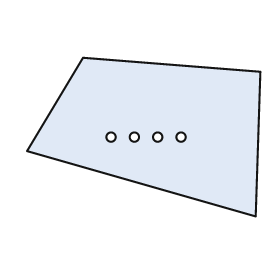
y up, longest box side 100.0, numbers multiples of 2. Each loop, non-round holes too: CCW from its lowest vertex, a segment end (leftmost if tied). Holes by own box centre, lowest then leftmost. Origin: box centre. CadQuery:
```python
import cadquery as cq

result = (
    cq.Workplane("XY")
    .moveTo(48.0, -34.0)
    .lineTo(50.0, 28.0)
    .lineTo(-26.0, 34.0)
    .lineTo(-50.0, -6.0)
    .close()
    .moveTo(-14.0, 0.0)
    .circle(2.0)
    .moveTo(-4.0, 0.0)
    .circle(2.0)
    .moveTo(6.0, 0.0)
    .circle(2.0)
    .moveTo(16.0, 0.0)
    .circle(2.0)
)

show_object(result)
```